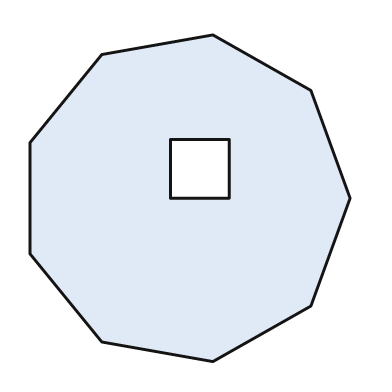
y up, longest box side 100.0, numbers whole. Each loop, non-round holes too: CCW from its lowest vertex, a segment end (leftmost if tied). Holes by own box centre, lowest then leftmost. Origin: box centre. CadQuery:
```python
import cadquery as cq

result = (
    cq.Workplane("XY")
    .moveTo(7.0, -50.0)
    .lineTo(37.0, -33.0)
    .lineTo(49.0, 0.0)
    .lineTo(37.0, 33.0)
    .lineTo(7.0, 50.0)
    .lineTo(-27.0, 44.0)
    .lineTo(-49.0, 17.0)
    .lineTo(-49.0, -17.0)
    .lineTo(-27.0, -44.0)
    .close()
    .moveTo(-6.0, 0.0)
    .lineTo(12.0, 0.0)
    .lineTo(12.0, 18.0)
    .lineTo(-6.0, 18.0)
    .close()
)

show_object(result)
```